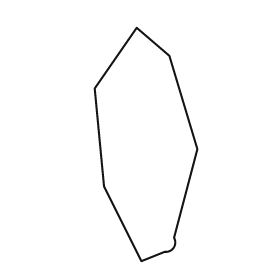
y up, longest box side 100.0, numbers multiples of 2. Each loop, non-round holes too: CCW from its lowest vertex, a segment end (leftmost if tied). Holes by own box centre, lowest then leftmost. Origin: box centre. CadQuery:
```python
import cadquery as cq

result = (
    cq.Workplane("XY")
    .moveTo(-2.0, -50.0)
    .lineTo(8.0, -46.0)
    .threePointArc((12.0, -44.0), (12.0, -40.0))
    .lineTo(22.0, -2.0)
    .lineTo(10.0, 38.0)
    .lineTo(-4.0, 50.0)
    .lineTo(-22.0, 24.0)
    .lineTo(-18.0, -18.0)
    .close()
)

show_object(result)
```